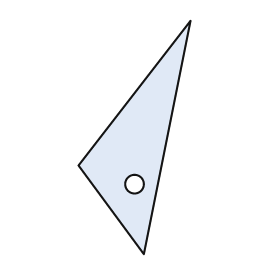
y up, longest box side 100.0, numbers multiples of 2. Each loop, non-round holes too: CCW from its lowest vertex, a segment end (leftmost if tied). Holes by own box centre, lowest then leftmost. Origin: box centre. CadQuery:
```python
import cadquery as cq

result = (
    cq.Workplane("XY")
    .moveTo(4.0, -50.0)
    .lineTo(24.0, 50.0)
    .lineTo(-24.0, -12.0)
    .close()
    .moveTo(0.0, -20.0)
    .circle(4.0)
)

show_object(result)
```